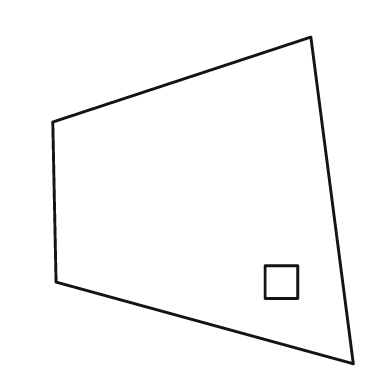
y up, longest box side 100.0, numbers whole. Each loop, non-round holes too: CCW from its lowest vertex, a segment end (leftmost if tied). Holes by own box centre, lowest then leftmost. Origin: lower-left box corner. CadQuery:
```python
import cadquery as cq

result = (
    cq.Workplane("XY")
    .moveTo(92.0, 0.0)
    .lineTo(79.0, 100.0)
    .lineTo(0.0, 74.0)
    .lineTo(1.0, 25.0)
    .close()
    .moveTo(65.0, 20.0)
    .lineTo(75.0, 20.0)
    .lineTo(75.0, 30.0)
    .lineTo(65.0, 30.0)
    .close()
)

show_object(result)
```